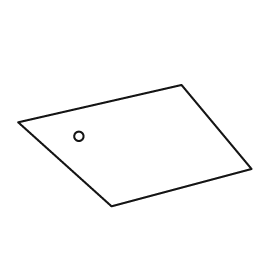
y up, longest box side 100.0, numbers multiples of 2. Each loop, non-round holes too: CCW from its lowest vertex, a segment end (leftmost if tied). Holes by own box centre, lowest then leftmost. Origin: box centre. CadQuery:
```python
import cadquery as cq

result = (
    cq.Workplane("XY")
    .moveTo(-10.0, -26.0)
    .lineTo(50.0, -10.0)
    .lineTo(20.0, 26.0)
    .lineTo(-50.0, 10.0)
    .close()
    .moveTo(-24.0, 4.0)
    .circle(2.0)
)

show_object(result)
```